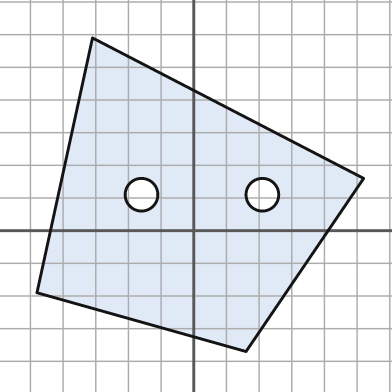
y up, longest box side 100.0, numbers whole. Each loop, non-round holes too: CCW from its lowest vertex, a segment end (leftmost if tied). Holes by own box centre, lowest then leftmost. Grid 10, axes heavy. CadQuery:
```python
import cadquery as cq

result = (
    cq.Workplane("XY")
    .moveTo(16.0, -37.0)
    .lineTo(52.0, 16.0)
    .lineTo(-31.0, 59.0)
    .lineTo(-48.0, -19.0)
    .close()
    .moveTo(-16.0, 11.0)
    .circle(5.0)
    .moveTo(21.0, 11.0)
    .circle(5.0)
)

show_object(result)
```